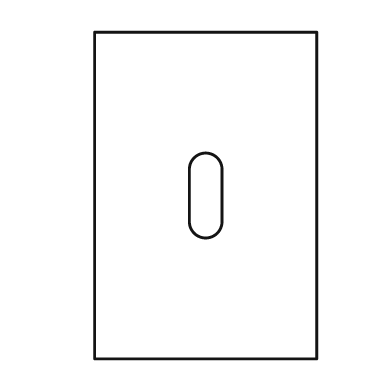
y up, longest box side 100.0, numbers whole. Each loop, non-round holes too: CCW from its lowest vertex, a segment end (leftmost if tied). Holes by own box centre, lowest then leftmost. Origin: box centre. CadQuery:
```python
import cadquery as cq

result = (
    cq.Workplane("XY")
    .moveTo(-34.0, -50.0)
    .lineTo(34.0, -50.0)
    .lineTo(34.0, 50.0)
    .lineTo(-34.0, 50.0)
    .close()
    .moveTo(-5.0, -8.0)
    .threePointArc((0.0, -13.0), (5.0, -8.0))
    .lineTo(5.0, 8.0)
    .threePointArc((0.0, 13.0), (-5.0, 8.0))
    .close()
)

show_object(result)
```